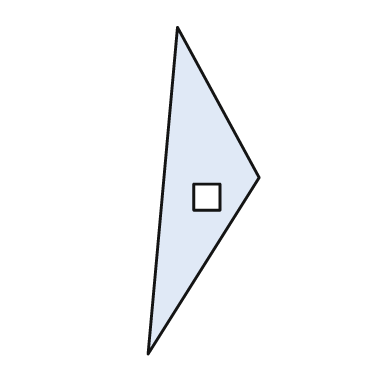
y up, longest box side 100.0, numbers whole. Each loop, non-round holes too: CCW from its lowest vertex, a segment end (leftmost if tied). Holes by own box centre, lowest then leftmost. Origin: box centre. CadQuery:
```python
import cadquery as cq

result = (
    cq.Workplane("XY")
    .moveTo(-17.0, -50.0)
    .lineTo(17.0, 4.0)
    .lineTo(-8.0, 50.0)
    .close()
    .moveTo(-3.0, -6.0)
    .lineTo(5.0, -6.0)
    .lineTo(5.0, 2.0)
    .lineTo(-3.0, 2.0)
    .close()
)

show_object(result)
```